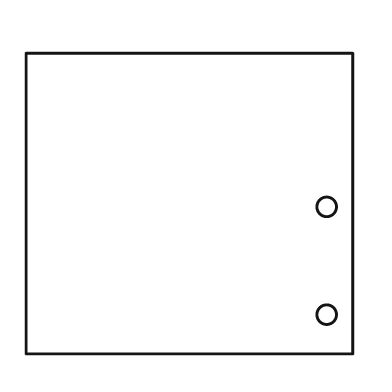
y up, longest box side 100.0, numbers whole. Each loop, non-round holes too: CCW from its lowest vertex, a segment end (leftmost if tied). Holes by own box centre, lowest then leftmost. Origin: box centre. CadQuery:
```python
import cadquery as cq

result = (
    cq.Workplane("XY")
    .moveTo(-50.0, -46.0)
    .lineTo(50.0, -46.0)
    .lineTo(50.0, 46.0)
    .lineTo(-50.0, 46.0)
    .close()
    .moveTo(42.0, -34.0)
    .circle(3.0)
    .moveTo(42.0, -1.0)
    .circle(3.0)
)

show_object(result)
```